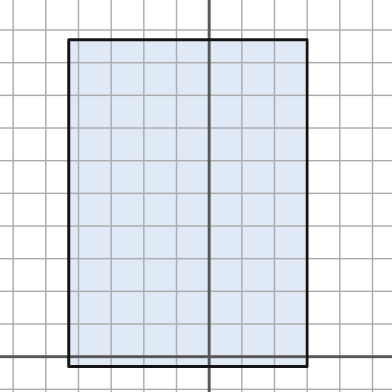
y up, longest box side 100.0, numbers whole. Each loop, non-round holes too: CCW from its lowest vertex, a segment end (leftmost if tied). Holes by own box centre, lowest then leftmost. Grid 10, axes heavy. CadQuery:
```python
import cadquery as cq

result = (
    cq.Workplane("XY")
    .moveTo(-43.0, -3.0)
    .lineTo(30.0, -3.0)
    .lineTo(30.0, 97.0)
    .lineTo(-43.0, 97.0)
    .close()
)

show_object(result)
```